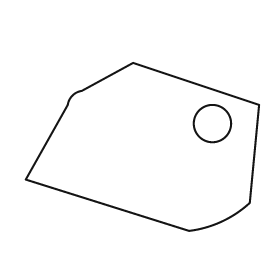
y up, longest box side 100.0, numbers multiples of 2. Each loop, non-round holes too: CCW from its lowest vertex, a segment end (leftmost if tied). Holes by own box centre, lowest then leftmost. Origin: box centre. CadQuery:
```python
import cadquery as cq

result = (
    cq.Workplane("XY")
    .moveTo(20.0, -36.0)
    .threePointArc((34.0, -32.0), (46.0, -24.0))
    .lineTo(50.0, 18.0)
    .lineTo(-4.0, 36.0)
    .lineTo(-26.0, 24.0)
    .threePointArc((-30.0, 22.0), (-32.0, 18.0))
    .lineTo(-50.0, -14.0)
    .close()
    .moveTo(30.0, 10.0)
    .circle(8.0)
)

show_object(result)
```